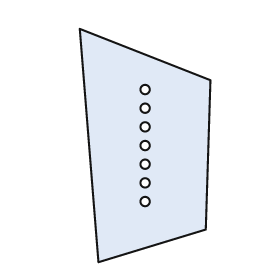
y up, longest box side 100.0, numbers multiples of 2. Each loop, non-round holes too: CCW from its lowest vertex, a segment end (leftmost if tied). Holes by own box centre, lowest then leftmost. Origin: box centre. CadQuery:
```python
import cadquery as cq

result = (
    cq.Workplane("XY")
    .moveTo(-20.0, -50.0)
    .lineTo(26.0, -36.0)
    .lineTo(28.0, 28.0)
    .lineTo(-28.0, 50.0)
    .close()
    .moveTo(0.0, -24.0)
    .circle(2.0)
    .moveTo(0.0, -16.0)
    .circle(2.0)
    .moveTo(0.0, -8.0)
    .circle(2.0)
    .moveTo(0.0, 0.0)
    .circle(2.0)
    .moveTo(0.0, 8.0)
    .circle(2.0)
    .moveTo(0.0, 16.0)
    .circle(2.0)
    .moveTo(0.0, 24.0)
    .circle(2.0)
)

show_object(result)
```